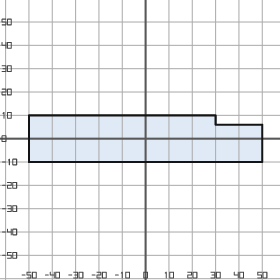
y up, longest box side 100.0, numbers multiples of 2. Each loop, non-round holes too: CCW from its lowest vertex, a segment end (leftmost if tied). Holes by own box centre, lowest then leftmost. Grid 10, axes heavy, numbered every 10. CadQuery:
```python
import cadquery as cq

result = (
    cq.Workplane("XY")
    .moveTo(-50.0, -10.0)
    .lineTo(50.0, -10.0)
    .lineTo(50.0, 6.0)
    .lineTo(30.0, 6.0)
    .lineTo(30.0, 10.0)
    .lineTo(-50.0, 10.0)
    .close()
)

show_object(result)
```